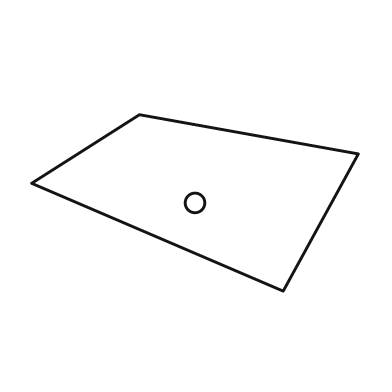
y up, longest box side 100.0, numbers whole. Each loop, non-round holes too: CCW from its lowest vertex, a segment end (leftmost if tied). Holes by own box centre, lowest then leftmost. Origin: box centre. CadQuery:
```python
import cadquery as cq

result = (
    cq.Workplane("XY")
    .moveTo(27.0, -27.0)
    .lineTo(50.0, 15.0)
    .lineTo(-17.0, 27.0)
    .lineTo(-50.0, 6.0)
    .close()
    .moveTo(0.0, 0.0)
    .circle(3.0)
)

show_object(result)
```